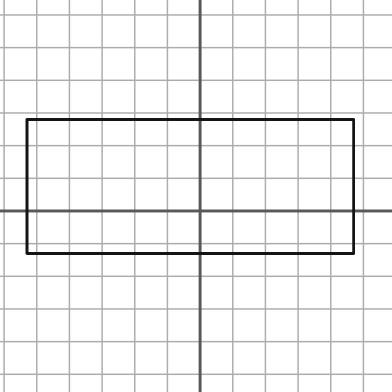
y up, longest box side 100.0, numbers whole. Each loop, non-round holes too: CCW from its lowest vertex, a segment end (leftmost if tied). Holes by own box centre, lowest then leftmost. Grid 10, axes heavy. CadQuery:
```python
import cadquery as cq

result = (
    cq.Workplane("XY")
    .moveTo(-53.0, -13.0)
    .lineTo(47.0, -13.0)
    .lineTo(47.0, 28.0)
    .lineTo(-53.0, 28.0)
    .close()
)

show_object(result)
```